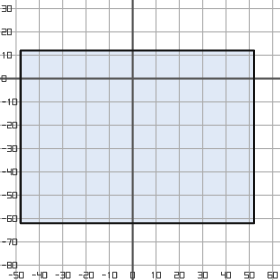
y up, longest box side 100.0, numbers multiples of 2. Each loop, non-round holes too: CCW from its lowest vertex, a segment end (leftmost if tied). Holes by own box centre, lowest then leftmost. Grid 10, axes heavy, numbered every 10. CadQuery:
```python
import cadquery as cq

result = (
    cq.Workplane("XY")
    .moveTo(-48.0, -62.0)
    .lineTo(52.0, -62.0)
    .lineTo(52.0, 12.0)
    .lineTo(-48.0, 12.0)
    .close()
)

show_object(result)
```